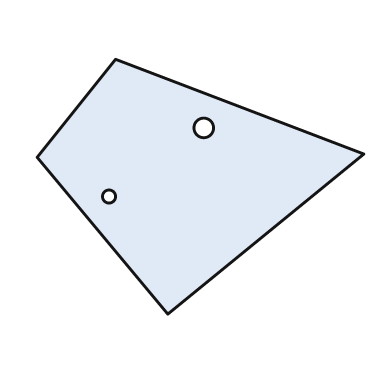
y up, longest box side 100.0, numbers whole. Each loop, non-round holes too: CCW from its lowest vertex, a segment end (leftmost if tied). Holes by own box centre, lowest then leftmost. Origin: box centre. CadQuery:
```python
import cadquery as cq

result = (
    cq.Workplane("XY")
    .moveTo(-10.0, -39.0)
    .lineTo(50.0, 10.0)
    .lineTo(-26.0, 39.0)
    .lineTo(-50.0, 9.0)
    .close()
    .moveTo(-28.0, -3.0)
    .circle(2.0)
    .moveTo(1.0, 18.0)
    .circle(3.0)
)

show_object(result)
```